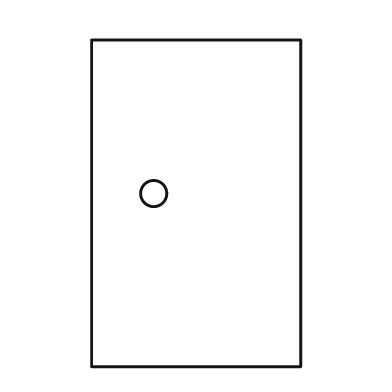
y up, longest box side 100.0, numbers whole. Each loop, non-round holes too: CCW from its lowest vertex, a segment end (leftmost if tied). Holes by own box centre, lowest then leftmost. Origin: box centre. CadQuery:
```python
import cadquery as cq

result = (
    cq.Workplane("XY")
    .moveTo(-32.0, -50.0)
    .lineTo(32.0, -50.0)
    .lineTo(32.0, 50.0)
    .lineTo(-32.0, 50.0)
    .close()
    .moveTo(-13.0, 3.0)
    .circle(4.0)
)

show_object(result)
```